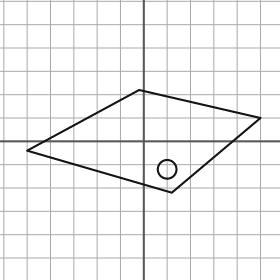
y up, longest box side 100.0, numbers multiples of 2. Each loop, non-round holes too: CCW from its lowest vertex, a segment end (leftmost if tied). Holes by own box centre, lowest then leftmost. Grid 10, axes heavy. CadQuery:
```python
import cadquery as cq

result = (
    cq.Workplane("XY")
    .moveTo(12.0, -22.0)
    .lineTo(50.0, 10.0)
    .lineTo(-2.0, 22.0)
    .lineTo(-50.0, -4.0)
    .close()
    .moveTo(10.0, -12.0)
    .circle(4.0)
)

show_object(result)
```